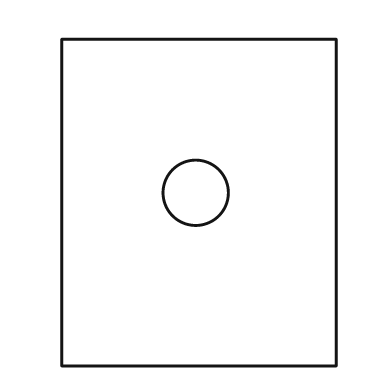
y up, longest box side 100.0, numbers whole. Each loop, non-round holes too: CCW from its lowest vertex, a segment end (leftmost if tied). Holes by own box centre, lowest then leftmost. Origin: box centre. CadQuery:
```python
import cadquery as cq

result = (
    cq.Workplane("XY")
    .moveTo(-42.0, -50.0)
    .lineTo(42.0, -50.0)
    .lineTo(42.0, 50.0)
    .lineTo(-42.0, 50.0)
    .close()
    .moveTo(-1.0, 3.0)
    .circle(10.0)
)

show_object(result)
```